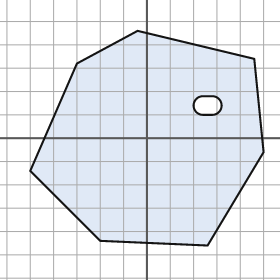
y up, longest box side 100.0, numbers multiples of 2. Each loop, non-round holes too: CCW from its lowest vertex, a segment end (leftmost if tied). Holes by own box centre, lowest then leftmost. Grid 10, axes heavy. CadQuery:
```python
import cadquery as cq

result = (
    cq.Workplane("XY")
    .moveTo(26.0, -46.0)
    .lineTo(50.0, -6.0)
    .lineTo(46.0, 34.0)
    .lineTo(-4.0, 46.0)
    .lineTo(-30.0, 32.0)
    .lineTo(-50.0, -14.0)
    .lineTo(-20.0, -44.0)
    .close()
    .moveTo(24.0, 10.0)
    .lineTo(28.0, 10.0)
    .threePointArc((32.0, 14.0), (28.0, 18.0))
    .lineTo(24.0, 18.0)
    .threePointArc((20.0, 14.0), (24.0, 10.0))
    .close()
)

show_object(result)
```